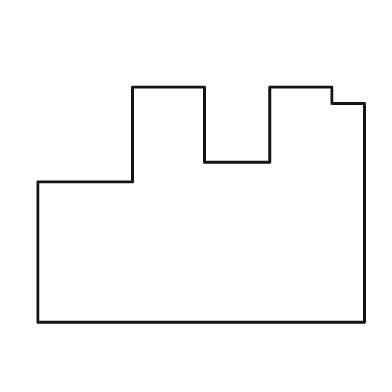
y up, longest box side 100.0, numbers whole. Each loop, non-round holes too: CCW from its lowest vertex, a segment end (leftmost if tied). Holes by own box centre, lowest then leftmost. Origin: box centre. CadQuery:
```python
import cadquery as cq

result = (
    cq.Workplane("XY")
    .moveTo(-50.0, -36.0)
    .lineTo(50.0, -36.0)
    .lineTo(50.0, 31.0)
    .lineTo(40.0, 31.0)
    .lineTo(40.0, 36.0)
    .lineTo(21.0, 36.0)
    .lineTo(21.0, 13.0)
    .lineTo(1.0, 13.0)
    .lineTo(1.0, 36.0)
    .lineTo(-21.0, 36.0)
    .lineTo(-21.0, 7.0)
    .lineTo(-50.0, 7.0)
    .close()
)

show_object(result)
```